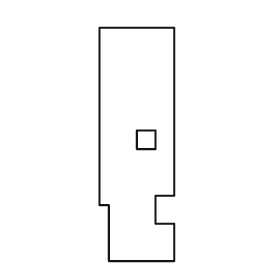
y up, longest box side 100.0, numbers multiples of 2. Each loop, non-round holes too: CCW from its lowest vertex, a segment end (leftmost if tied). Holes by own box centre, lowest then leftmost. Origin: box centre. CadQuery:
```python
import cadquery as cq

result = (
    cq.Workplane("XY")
    .moveTo(-12.0, -50.0)
    .lineTo(16.0, -50.0)
    .lineTo(16.0, -34.0)
    .lineTo(8.0, -34.0)
    .lineTo(8.0, -22.0)
    .lineTo(16.0, -22.0)
    .lineTo(16.0, 50.0)
    .lineTo(-16.0, 50.0)
    .lineTo(-16.0, -26.0)
    .lineTo(-12.0, -26.0)
    .close()
    .moveTo(0.0, -2.0)
    .lineTo(8.0, -2.0)
    .lineTo(8.0, 6.0)
    .lineTo(0.0, 6.0)
    .close()
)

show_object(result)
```